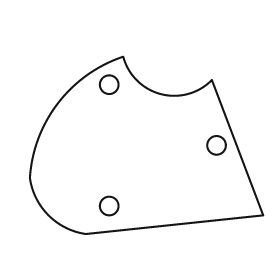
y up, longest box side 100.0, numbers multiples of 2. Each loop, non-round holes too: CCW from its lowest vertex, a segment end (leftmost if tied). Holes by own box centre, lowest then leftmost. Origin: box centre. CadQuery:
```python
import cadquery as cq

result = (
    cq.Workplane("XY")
    .moveTo(-26.0, -38.0)
    .lineTo(50.0, -30.0)
    .lineTo(28.0, 28.0)
    .threePointArc((6.0, 22.0), (-10.0, 38.0))
    .threePointArc((-38.0, 18.0), (-50.0, -14.0))
    .threePointArc((-42.0, -30.0), (-26.0, -38.0))
    .close()
    .moveTo(-16.0, -26.0)
    .circle(4.0)
    .moveTo(30.0, 0.0)
    .circle(4.0)
    .moveTo(-16.0, 26.0)
    .circle(4.0)
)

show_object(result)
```